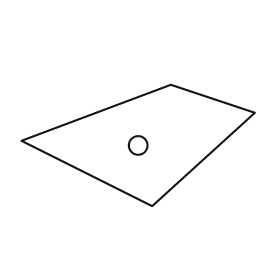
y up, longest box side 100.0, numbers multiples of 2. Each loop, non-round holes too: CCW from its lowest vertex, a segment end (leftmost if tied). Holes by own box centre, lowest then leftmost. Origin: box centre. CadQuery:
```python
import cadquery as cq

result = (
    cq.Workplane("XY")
    .moveTo(6.0, -26.0)
    .lineTo(50.0, 14.0)
    .lineTo(14.0, 26.0)
    .lineTo(-50.0, 2.0)
    .close()
    .moveTo(0.0, 0.0)
    .circle(4.0)
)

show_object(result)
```